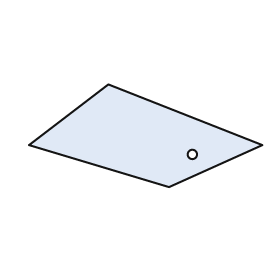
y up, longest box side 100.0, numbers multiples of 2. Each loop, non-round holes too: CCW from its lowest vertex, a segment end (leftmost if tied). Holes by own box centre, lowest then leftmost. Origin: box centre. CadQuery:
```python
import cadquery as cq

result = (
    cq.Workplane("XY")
    .moveTo(10.0, -22.0)
    .lineTo(50.0, -4.0)
    .lineTo(-16.0, 22.0)
    .lineTo(-50.0, -4.0)
    .close()
    .moveTo(20.0, -8.0)
    .circle(2.0)
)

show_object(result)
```